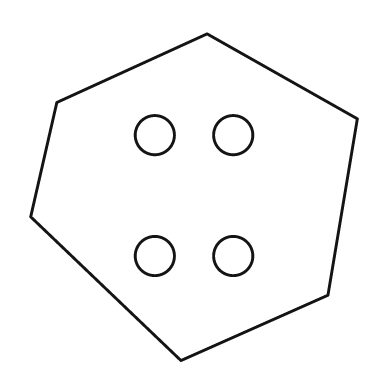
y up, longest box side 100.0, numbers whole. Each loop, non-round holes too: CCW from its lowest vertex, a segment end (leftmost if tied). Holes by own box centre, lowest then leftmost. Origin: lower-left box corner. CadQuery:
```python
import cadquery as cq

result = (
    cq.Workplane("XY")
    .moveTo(46.0, 0.0)
    .lineTo(91.0, 20.0)
    .lineTo(100.0, 74.0)
    .lineTo(54.0, 100.0)
    .lineTo(8.0, 79.0)
    .lineTo(0.0, 44.0)
    .close()
    .moveTo(38.0, 32.0)
    .circle(6.0)
    .moveTo(62.0, 32.0)
    .circle(6.0)
    .moveTo(38.0, 69.0)
    .circle(6.0)
    .moveTo(62.0, 69.0)
    .circle(6.0)
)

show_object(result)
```